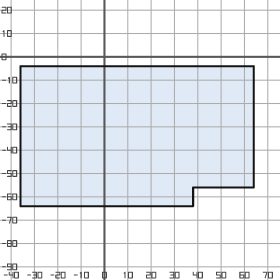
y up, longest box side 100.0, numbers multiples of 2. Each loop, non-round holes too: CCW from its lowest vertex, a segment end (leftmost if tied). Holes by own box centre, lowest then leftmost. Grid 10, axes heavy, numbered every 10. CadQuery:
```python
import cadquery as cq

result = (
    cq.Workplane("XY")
    .moveTo(-36.0, -64.0)
    .lineTo(38.0, -64.0)
    .lineTo(38.0, -56.0)
    .lineTo(64.0, -56.0)
    .lineTo(64.0, -4.0)
    .lineTo(-36.0, -4.0)
    .close()
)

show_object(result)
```